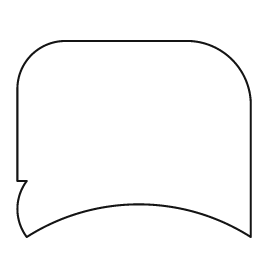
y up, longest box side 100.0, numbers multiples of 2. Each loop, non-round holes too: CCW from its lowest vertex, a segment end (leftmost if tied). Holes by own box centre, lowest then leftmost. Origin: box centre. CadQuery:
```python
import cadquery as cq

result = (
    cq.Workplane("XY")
    .moveTo(-46.0, -42.0)
    .threePointArc((2.0, -28.0), (50.0, -42.0))
    .lineTo(50.0, 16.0)
    .threePointArc((42.0, 34.0), (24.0, 42.0))
    .lineTo(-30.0, 42.0)
    .threePointArc((-44.0, 36.0), (-50.0, 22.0))
    .lineTo(-50.0, -18.0)
    .lineTo(-46.0, -18.0)
    .threePointArc((-50.0, -30.0), (-46.0, -42.0))
    .close()
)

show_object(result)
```